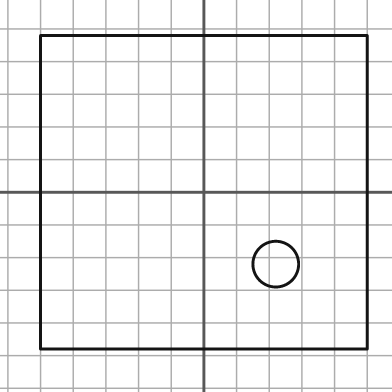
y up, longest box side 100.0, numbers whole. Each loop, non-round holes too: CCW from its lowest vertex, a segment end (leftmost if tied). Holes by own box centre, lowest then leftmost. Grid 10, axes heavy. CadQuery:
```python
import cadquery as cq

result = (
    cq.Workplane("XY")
    .moveTo(-50.0, -48.0)
    .lineTo(50.0, -48.0)
    .lineTo(50.0, 48.0)
    .lineTo(-50.0, 48.0)
    .close()
    .moveTo(22.0, -22.0)
    .circle(7.0)
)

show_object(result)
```